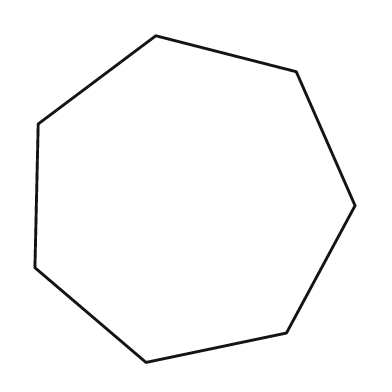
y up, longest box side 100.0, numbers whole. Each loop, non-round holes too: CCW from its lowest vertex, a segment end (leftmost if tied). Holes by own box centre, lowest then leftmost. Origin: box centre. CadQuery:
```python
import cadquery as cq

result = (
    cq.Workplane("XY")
    .moveTo(-15.0, -50.0)
    .lineTo(28.0, -41.0)
    .lineTo(49.0, -2.0)
    .lineTo(31.0, 39.0)
    .lineTo(-12.0, 50.0)
    .lineTo(-48.0, 23.0)
    .lineTo(-49.0, -21.0)
    .close()
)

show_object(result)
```